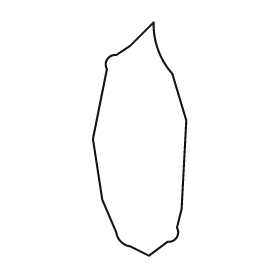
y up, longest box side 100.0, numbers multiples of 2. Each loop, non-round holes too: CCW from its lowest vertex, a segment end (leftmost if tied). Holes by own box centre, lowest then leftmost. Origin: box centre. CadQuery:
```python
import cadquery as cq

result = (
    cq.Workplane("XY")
    .moveTo(4.0, -50.0)
    .lineTo(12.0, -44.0)
    .threePointArc((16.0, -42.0), (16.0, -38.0))
    .lineTo(18.0, -30.0)
    .lineTo(20.0, 8.0)
    .lineTo(14.0, 28.0)
    .threePointArc((8.0, 38.0), (6.0, 50.0))
    .lineTo(-4.0, 40.0)
    .lineTo(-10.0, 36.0)
    .threePointArc((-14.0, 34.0), (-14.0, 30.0))
    .lineTo(-20.0, 0.0)
    .lineTo(-16.0, -26.0)
    .lineTo(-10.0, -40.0)
    .threePointArc((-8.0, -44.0), (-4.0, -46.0))
    .close()
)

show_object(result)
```